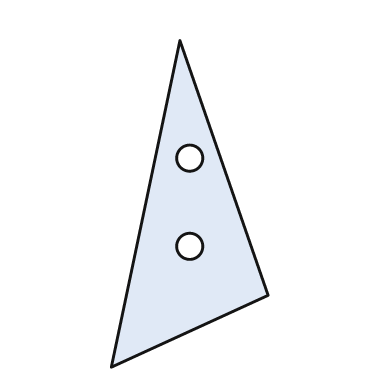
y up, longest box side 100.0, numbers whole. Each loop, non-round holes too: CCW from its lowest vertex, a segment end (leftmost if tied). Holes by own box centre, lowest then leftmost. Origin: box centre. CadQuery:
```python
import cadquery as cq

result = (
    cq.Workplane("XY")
    .moveTo(-24.0, -50.0)
    .lineTo(24.0, -28.0)
    .lineTo(-3.0, 50.0)
    .close()
    .moveTo(0.0, -13.0)
    .circle(4.0)
    .moveTo(0.0, 14.0)
    .circle(4.0)
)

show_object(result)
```